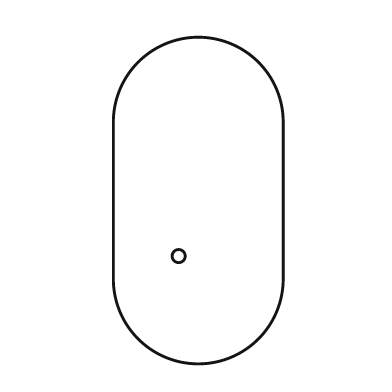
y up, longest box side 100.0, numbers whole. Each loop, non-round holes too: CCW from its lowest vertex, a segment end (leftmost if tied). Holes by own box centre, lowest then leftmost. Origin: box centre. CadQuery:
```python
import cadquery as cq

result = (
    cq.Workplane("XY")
    .moveTo(-26.0, -24.0)
    .threePointArc((0.0, -50.0), (26.0, -24.0))
    .lineTo(26.0, 24.0)
    .threePointArc((0.0, 50.0), (-26.0, 24.0))
    .close()
    .moveTo(-6.0, -17.0)
    .circle(2.0)
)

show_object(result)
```